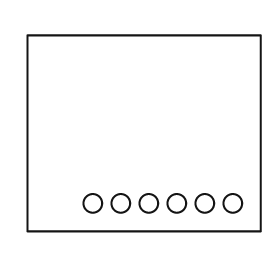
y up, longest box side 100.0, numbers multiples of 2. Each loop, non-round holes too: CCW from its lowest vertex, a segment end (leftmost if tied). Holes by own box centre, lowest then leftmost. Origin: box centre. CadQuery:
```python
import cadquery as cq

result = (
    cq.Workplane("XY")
    .moveTo(-50.0, -42.0)
    .lineTo(50.0, -42.0)
    .lineTo(50.0, 42.0)
    .lineTo(-50.0, 42.0)
    .close()
    .moveTo(-22.0, -30.0)
    .circle(4.0)
    .moveTo(-10.0, -30.0)
    .circle(4.0)
    .moveTo(2.0, -30.0)
    .circle(4.0)
    .moveTo(14.0, -30.0)
    .circle(4.0)
    .moveTo(26.0, -30.0)
    .circle(4.0)
    .moveTo(38.0, -30.0)
    .circle(4.0)
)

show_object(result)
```